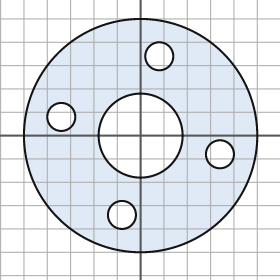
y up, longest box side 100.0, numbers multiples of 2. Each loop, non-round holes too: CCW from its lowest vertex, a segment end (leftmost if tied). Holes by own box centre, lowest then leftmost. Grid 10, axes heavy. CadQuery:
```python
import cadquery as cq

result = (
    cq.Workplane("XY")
    .moveTo(0.0, 0.0)
    .circle(50.0)
    .moveTo(-8.0, -34.0)
    .circle(6.0)
    .moveTo(34.0, -8.0)
    .circle(6.0)
    .moveTo(0.0, 0.0)
    .circle(18.0)
    .moveTo(-34.0, 8.0)
    .circle(6.0)
    .moveTo(8.0, 34.0)
    .circle(6.0)
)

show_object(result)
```